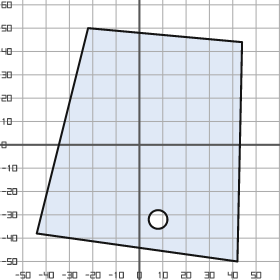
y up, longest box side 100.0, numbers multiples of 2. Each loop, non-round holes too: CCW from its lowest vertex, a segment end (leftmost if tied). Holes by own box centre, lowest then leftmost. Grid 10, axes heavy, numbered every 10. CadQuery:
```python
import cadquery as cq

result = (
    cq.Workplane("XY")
    .moveTo(42.0, -50.0)
    .lineTo(44.0, 44.0)
    .lineTo(-22.0, 50.0)
    .lineTo(-44.0, -38.0)
    .close()
    .moveTo(8.0, -32.0)
    .circle(4.0)
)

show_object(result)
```